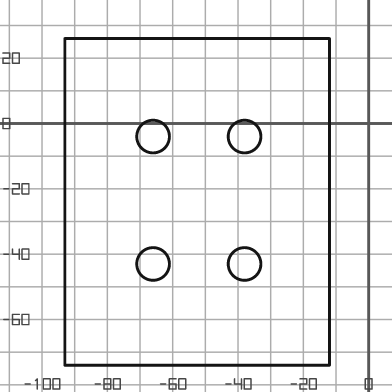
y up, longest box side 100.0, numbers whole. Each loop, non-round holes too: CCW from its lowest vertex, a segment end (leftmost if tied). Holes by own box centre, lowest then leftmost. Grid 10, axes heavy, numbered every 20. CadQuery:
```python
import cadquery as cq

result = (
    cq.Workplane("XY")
    .moveTo(-93.0, -74.0)
    .lineTo(-12.0, -74.0)
    .lineTo(-12.0, 26.0)
    .lineTo(-93.0, 26.0)
    .close()
    .moveTo(-66.0, -43.0)
    .circle(5.0)
    .moveTo(-38.0, -43.0)
    .circle(5.0)
    .moveTo(-66.0, -4.0)
    .circle(5.0)
    .moveTo(-38.0, -4.0)
    .circle(5.0)
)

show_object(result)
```